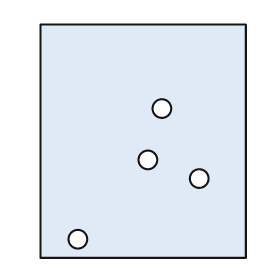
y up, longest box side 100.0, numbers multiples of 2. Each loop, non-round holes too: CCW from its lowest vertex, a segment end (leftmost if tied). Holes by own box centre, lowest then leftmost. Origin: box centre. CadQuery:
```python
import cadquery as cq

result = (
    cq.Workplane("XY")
    .moveTo(-44.0, -50.0)
    .lineTo(44.0, -50.0)
    .lineTo(44.0, 50.0)
    .lineTo(-44.0, 50.0)
    .close()
    .moveTo(-28.0, -42.0)
    .circle(4.0)
    .moveTo(24.0, -16.0)
    .circle(4.0)
    .moveTo(2.0, -8.0)
    .circle(4.0)
    .moveTo(8.0, 14.0)
    .circle(4.0)
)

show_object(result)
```